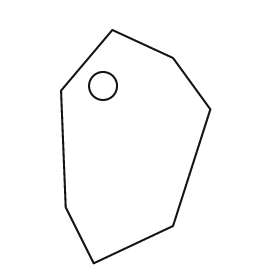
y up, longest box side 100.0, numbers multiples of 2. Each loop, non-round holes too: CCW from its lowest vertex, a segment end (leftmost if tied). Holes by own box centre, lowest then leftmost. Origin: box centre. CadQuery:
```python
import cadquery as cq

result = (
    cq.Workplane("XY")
    .moveTo(-18.0, -50.0)
    .lineTo(16.0, -34.0)
    .lineTo(32.0, 16.0)
    .lineTo(16.0, 38.0)
    .lineTo(-10.0, 50.0)
    .lineTo(-32.0, 24.0)
    .lineTo(-30.0, -26.0)
    .close()
    .moveTo(-14.0, 26.0)
    .circle(6.0)
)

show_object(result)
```